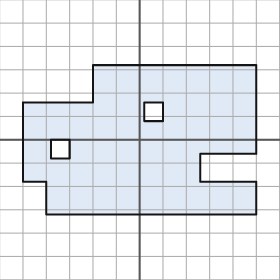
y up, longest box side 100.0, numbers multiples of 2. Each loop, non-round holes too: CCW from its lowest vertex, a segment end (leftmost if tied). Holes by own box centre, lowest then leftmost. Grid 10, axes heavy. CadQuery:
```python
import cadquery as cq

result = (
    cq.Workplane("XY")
    .moveTo(-40.0, -32.0)
    .lineTo(50.0, -32.0)
    .lineTo(50.0, -18.0)
    .lineTo(26.0, -18.0)
    .lineTo(26.0, -6.0)
    .lineTo(50.0, -6.0)
    .lineTo(50.0, 32.0)
    .lineTo(-20.0, 32.0)
    .lineTo(-20.0, 16.0)
    .lineTo(-50.0, 16.0)
    .lineTo(-50.0, -18.0)
    .lineTo(-40.0, -18.0)
    .close()
    .moveTo(-38.0, -8.0)
    .lineTo(-30.0, -8.0)
    .lineTo(-30.0, 0.0)
    .lineTo(-38.0, 0.0)
    .close()
    .moveTo(2.0, 8.0)
    .lineTo(10.0, 8.0)
    .lineTo(10.0, 16.0)
    .lineTo(2.0, 16.0)
    .close()
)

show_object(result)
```